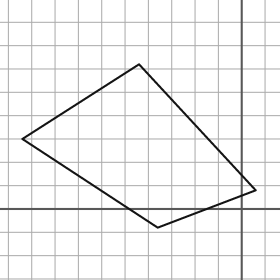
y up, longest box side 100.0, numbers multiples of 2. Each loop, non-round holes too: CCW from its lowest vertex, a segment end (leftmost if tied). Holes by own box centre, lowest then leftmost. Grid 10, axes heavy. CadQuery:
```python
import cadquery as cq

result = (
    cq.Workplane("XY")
    .moveTo(-36.0, -8.0)
    .lineTo(6.0, 8.0)
    .lineTo(-44.0, 62.0)
    .lineTo(-94.0, 30.0)
    .close()
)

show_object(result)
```